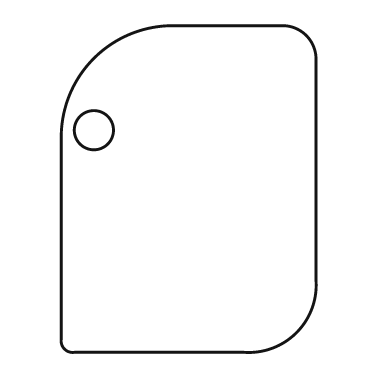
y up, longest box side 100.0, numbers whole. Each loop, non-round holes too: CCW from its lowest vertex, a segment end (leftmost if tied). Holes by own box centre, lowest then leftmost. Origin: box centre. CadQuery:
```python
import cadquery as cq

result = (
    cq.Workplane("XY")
    .moveTo(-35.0, -50.0)
    .lineTo(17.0, -50.0)
    .threePointArc((33.0, -44.0), (39.0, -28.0))
    .lineTo(39.0, 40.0)
    .threePointArc((36.0, 47.0), (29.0, 50.0))
    .lineTo(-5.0, 50.0)
    .threePointArc((-29.0, 40.0), (-39.0, 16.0))
    .lineTo(-39.0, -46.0)
    .threePointArc((-38.0, -49.0), (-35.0, -50.0))
    .close()
    .moveTo(-29.0, 18.0)
    .circle(6.0)
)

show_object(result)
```